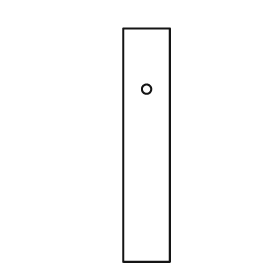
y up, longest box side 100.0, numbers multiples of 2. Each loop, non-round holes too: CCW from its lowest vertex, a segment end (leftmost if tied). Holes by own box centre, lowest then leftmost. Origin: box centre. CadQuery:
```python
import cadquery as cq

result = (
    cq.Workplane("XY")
    .moveTo(-10.0, -50.0)
    .lineTo(10.0, -50.0)
    .lineTo(10.0, 50.0)
    .lineTo(-10.0, 50.0)
    .close()
    .moveTo(0.0, 24.0)
    .circle(2.0)
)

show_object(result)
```